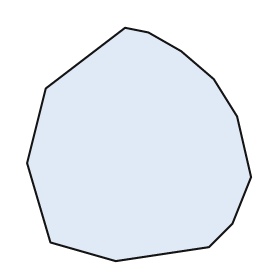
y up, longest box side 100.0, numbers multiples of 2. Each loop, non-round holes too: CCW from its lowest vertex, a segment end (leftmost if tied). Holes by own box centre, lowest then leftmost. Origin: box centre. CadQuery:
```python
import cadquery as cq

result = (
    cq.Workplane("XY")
    .moveTo(-10.0, -50.0)
    .lineTo(30.0, -44.0)
    .lineTo(40.0, -34.0)
    .lineTo(48.0, -14.0)
    .lineTo(42.0, 12.0)
    .lineTo(32.0, 28.0)
    .lineTo(18.0, 40.0)
    .lineTo(4.0, 48.0)
    .lineTo(-6.0, 50.0)
    .lineTo(-40.0, 24.0)
    .lineTo(-48.0, -8.0)
    .lineTo(-38.0, -42.0)
    .close()
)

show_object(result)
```